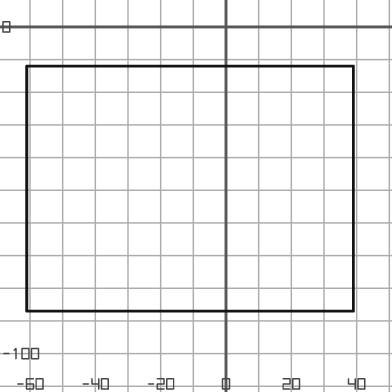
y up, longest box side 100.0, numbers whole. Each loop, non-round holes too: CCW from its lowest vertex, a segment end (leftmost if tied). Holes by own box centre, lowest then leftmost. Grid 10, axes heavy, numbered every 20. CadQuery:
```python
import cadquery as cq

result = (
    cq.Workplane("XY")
    .moveTo(-61.0, -87.0)
    .lineTo(39.0, -87.0)
    .lineTo(39.0, -12.0)
    .lineTo(-61.0, -12.0)
    .close()
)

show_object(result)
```